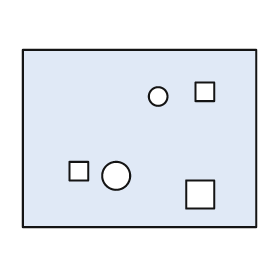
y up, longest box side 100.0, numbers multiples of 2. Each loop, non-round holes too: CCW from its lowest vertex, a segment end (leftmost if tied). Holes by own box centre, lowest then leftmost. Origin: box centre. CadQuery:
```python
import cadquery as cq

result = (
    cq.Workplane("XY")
    .moveTo(-50.0, -38.0)
    .lineTo(50.0, -38.0)
    .lineTo(50.0, 38.0)
    .lineTo(-50.0, 38.0)
    .close()
    .moveTo(20.0, -30.0)
    .lineTo(32.0, -30.0)
    .lineTo(32.0, -18.0)
    .lineTo(20.0, -18.0)
    .close()
    .moveTo(-10.0, -16.0)
    .circle(6.0)
    .moveTo(-30.0, -18.0)
    .lineTo(-22.0, -18.0)
    .lineTo(-22.0, -10.0)
    .lineTo(-30.0, -10.0)
    .close()
    .moveTo(8.0, 18.0)
    .circle(4.0)
    .moveTo(24.0, 16.0)
    .lineTo(32.0, 16.0)
    .lineTo(32.0, 24.0)
    .lineTo(24.0, 24.0)
    .close()
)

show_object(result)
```